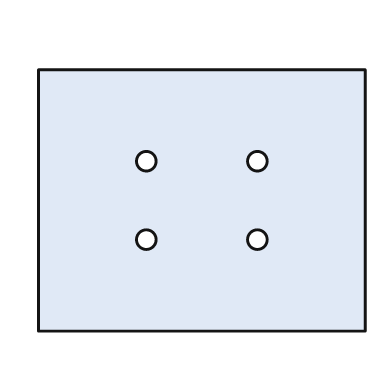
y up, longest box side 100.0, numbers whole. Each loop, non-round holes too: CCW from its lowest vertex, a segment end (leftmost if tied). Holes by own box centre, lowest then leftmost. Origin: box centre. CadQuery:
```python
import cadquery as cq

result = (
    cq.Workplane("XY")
    .moveTo(-50.0, -40.0)
    .lineTo(50.0, -40.0)
    .lineTo(50.0, 40.0)
    .lineTo(-50.0, 40.0)
    .close()
    .moveTo(-17.0, -12.0)
    .circle(3.0)
    .moveTo(17.0, -12.0)
    .circle(3.0)
    .moveTo(-17.0, 12.0)
    .circle(3.0)
    .moveTo(17.0, 12.0)
    .circle(3.0)
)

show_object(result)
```